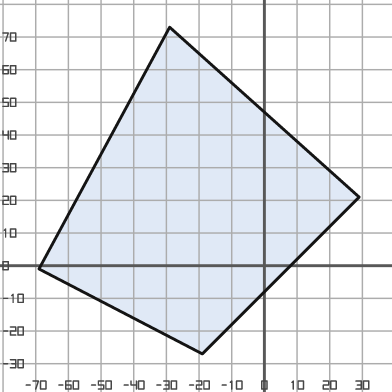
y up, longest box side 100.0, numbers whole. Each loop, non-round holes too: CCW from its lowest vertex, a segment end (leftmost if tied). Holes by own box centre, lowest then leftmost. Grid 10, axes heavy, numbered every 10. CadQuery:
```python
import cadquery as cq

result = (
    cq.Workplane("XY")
    .moveTo(-19.0, -27.0)
    .lineTo(29.0, 21.0)
    .lineTo(-29.0, 73.0)
    .lineTo(-69.0, -1.0)
    .close()
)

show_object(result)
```